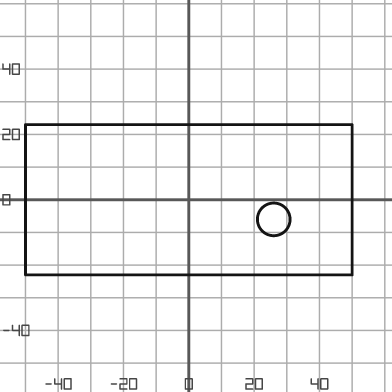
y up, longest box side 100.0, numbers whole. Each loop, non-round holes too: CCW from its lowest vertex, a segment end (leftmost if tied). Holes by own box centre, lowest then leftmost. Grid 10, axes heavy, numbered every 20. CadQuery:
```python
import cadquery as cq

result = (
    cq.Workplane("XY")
    .moveTo(-50.0, -23.0)
    .lineTo(50.0, -23.0)
    .lineTo(50.0, 23.0)
    .lineTo(-50.0, 23.0)
    .close()
    .moveTo(26.0, -6.0)
    .circle(5.0)
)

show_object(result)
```